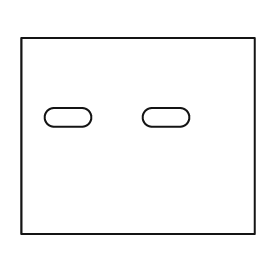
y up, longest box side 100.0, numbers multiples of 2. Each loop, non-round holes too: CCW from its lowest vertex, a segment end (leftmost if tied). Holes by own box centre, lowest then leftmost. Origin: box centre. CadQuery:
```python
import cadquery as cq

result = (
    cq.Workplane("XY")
    .moveTo(-50.0, -42.0)
    .lineTo(50.0, -42.0)
    .lineTo(50.0, 42.0)
    .lineTo(-50.0, 42.0)
    .close()
    .moveTo(-36.0, 4.0)
    .lineTo(-24.0, 4.0)
    .threePointArc((-20.0, 8.0), (-24.0, 12.0))
    .lineTo(-36.0, 12.0)
    .threePointArc((-40.0, 8.0), (-36.0, 4.0))
    .close()
    .moveTo(6.0, 4.0)
    .lineTo(18.0, 4.0)
    .threePointArc((22.0, 8.0), (18.0, 12.0))
    .lineTo(6.0, 12.0)
    .threePointArc((2.0, 8.0), (6.0, 4.0))
    .close()
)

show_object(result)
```